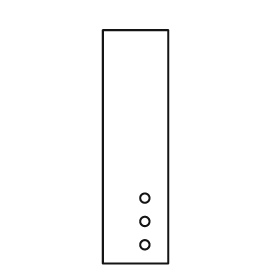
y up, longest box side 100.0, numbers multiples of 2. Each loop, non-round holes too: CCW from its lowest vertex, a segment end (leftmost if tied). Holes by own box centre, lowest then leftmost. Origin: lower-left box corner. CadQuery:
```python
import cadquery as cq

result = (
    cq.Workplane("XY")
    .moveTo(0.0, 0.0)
    .lineTo(28.0, 0.0)
    .lineTo(28.0, 100.0)
    .lineTo(0.0, 100.0)
    .close()
    .moveTo(18.0, 8.0)
    .circle(2.0)
    .moveTo(18.0, 18.0)
    .circle(2.0)
    .moveTo(18.0, 28.0)
    .circle(2.0)
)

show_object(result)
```